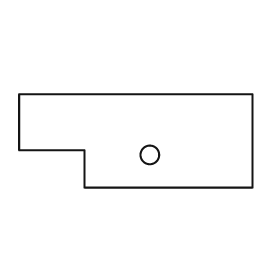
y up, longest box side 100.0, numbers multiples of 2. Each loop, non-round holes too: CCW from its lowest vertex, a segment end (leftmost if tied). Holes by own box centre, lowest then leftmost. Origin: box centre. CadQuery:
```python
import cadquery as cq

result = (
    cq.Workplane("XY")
    .moveTo(-22.0, -20.0)
    .lineTo(50.0, -20.0)
    .lineTo(50.0, 20.0)
    .lineTo(-50.0, 20.0)
    .lineTo(-50.0, -4.0)
    .lineTo(-22.0, -4.0)
    .close()
    .moveTo(6.0, -6.0)
    .circle(4.0)
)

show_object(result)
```